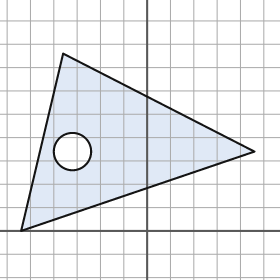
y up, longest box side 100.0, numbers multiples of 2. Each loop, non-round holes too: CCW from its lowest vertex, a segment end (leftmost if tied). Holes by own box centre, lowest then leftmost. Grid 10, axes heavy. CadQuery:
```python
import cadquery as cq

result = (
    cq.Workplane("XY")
    .moveTo(-54.0, 0.0)
    .lineTo(46.0, 34.0)
    .lineTo(-36.0, 76.0)
    .close()
    .moveTo(-32.0, 34.0)
    .circle(8.0)
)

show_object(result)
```